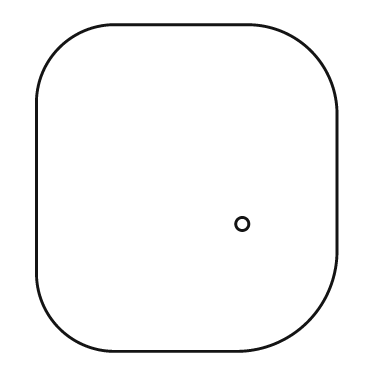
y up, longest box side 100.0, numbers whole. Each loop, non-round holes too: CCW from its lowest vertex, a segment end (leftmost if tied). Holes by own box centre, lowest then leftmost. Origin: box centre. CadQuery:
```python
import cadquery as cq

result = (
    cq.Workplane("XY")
    .moveTo(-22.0, -50.0)
    .lineTo(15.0, -50.0)
    .threePointArc((37.0, -41.0), (46.0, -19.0))
    .lineTo(46.0, 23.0)
    .threePointArc((38.0, 42.0), (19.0, 50.0))
    .lineTo(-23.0, 50.0)
    .threePointArc((-39.0, 43.0), (-46.0, 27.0))
    .lineTo(-46.0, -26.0)
    .threePointArc((-39.0, -43.0), (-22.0, -50.0))
    .close()
    .moveTo(17.0, -11.0)
    .circle(2.0)
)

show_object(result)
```